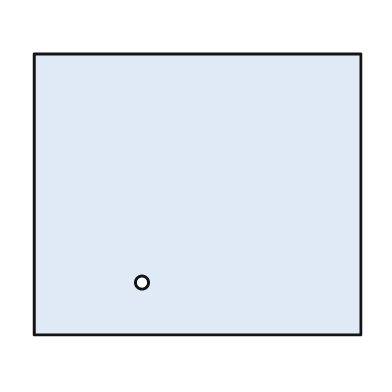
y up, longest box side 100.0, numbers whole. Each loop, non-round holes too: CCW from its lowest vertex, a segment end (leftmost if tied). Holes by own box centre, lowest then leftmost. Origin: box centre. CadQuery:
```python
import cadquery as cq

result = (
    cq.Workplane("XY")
    .moveTo(-50.0, -43.0)
    .lineTo(50.0, -43.0)
    .lineTo(50.0, 43.0)
    .lineTo(-50.0, 43.0)
    .close()
    .moveTo(-17.0, -27.0)
    .circle(2.0)
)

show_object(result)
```